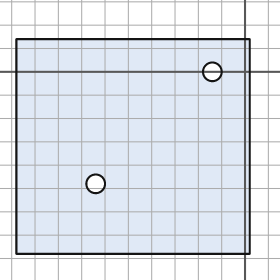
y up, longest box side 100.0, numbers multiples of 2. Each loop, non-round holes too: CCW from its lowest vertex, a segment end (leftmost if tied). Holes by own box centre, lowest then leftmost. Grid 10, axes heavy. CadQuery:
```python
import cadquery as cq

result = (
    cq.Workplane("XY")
    .moveTo(-98.0, -78.0)
    .lineTo(2.0, -78.0)
    .lineTo(2.0, 14.0)
    .lineTo(-98.0, 14.0)
    .close()
    .moveTo(-64.0, -48.0)
    .circle(4.0)
    .moveTo(-14.0, 0.0)
    .circle(4.0)
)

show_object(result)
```